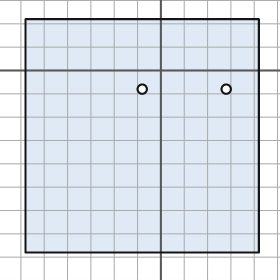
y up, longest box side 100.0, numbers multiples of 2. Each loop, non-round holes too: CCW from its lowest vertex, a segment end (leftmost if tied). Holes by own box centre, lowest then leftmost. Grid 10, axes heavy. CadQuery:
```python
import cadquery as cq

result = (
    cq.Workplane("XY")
    .moveTo(-58.0, -78.0)
    .lineTo(42.0, -78.0)
    .lineTo(42.0, 22.0)
    .lineTo(-58.0, 22.0)
    .close()
    .moveTo(-8.0, -8.0)
    .circle(2.0)
    .moveTo(28.0, -8.0)
    .circle(2.0)
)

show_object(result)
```